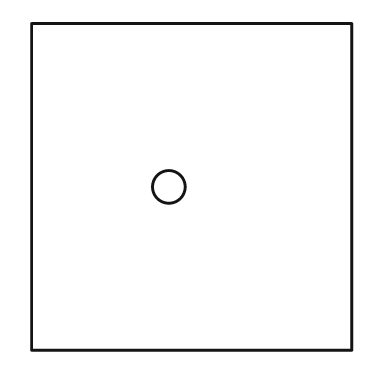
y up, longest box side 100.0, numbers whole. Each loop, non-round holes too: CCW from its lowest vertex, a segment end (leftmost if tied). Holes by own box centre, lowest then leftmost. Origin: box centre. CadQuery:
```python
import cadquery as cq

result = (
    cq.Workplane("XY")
    .moveTo(-49.0, -50.0)
    .lineTo(49.0, -50.0)
    .lineTo(49.0, 50.0)
    .lineTo(-49.0, 50.0)
    .close()
    .moveTo(-7.0, 0.0)
    .circle(5.0)
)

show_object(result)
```